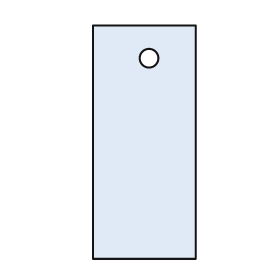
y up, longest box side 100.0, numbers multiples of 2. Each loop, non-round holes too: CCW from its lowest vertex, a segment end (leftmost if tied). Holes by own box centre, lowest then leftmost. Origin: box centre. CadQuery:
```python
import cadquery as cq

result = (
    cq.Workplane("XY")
    .moveTo(-22.0, -50.0)
    .lineTo(22.0, -50.0)
    .lineTo(22.0, 50.0)
    .lineTo(-22.0, 50.0)
    .close()
    .moveTo(2.0, 36.0)
    .circle(4.0)
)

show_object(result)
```